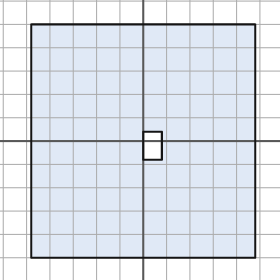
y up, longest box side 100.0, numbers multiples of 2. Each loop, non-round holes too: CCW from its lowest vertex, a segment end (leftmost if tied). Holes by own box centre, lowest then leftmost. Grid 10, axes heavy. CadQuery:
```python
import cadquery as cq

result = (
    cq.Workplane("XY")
    .moveTo(-48.0, -50.0)
    .lineTo(48.0, -50.0)
    .lineTo(48.0, 50.0)
    .lineTo(-48.0, 50.0)
    .close()
    .moveTo(0.0, -8.0)
    .lineTo(8.0, -8.0)
    .lineTo(8.0, 4.0)
    .lineTo(0.0, 4.0)
    .close()
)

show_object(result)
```